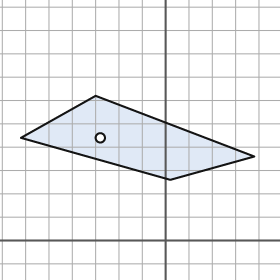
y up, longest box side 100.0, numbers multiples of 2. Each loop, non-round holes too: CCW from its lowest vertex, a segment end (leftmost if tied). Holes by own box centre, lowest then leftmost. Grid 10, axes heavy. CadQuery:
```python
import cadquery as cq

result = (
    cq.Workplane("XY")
    .moveTo(2.0, 26.0)
    .lineTo(38.0, 36.0)
    .lineTo(-30.0, 62.0)
    .lineTo(-62.0, 44.0)
    .close()
    .moveTo(-28.0, 44.0)
    .circle(2.0)
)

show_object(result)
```